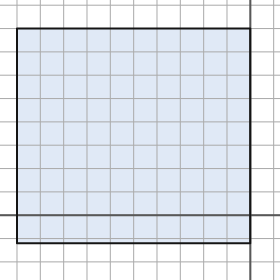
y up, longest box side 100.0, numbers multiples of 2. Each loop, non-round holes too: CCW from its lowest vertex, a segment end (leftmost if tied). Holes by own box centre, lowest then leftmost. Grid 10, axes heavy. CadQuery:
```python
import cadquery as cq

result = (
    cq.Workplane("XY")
    .moveTo(-100.0, -12.0)
    .lineTo(0.0, -12.0)
    .lineTo(0.0, 80.0)
    .lineTo(-100.0, 80.0)
    .close()
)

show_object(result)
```